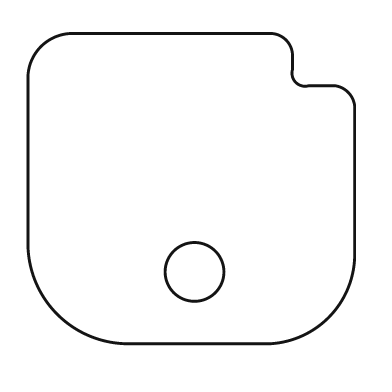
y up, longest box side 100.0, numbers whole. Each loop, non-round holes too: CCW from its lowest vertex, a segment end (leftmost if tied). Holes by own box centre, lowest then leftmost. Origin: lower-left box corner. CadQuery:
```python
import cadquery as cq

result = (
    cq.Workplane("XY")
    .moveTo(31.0, 0.0)
    .lineTo(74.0, 0.0)
    .threePointArc((92.0, 8.0), (100.0, 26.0))
    .lineTo(100.0, 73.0)
    .threePointArc((98.0, 77.0), (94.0, 79.0))
    .lineTo(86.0, 79.0)
    .threePointArc((82.0, 80.0), (81.0, 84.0))
    .lineTo(81.0, 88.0)
    .threePointArc((79.0, 93.0), (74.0, 95.0))
    .lineTo(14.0, 95.0)
    .threePointArc((4.0, 91.0), (0.0, 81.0))
    .lineTo(0.0, 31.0)
    .threePointArc((9.0, 9.0), (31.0, 0.0))
    .close()
    .moveTo(51.0, 22.0)
    .circle(9.0)
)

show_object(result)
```